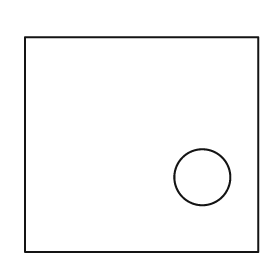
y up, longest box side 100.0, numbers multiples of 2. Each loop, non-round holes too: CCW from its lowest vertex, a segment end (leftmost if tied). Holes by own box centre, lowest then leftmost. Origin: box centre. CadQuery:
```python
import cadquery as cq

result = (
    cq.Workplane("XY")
    .moveTo(-50.0, -46.0)
    .lineTo(50.0, -46.0)
    .lineTo(50.0, 46.0)
    .lineTo(-50.0, 46.0)
    .close()
    .moveTo(26.0, -14.0)
    .circle(12.0)
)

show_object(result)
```